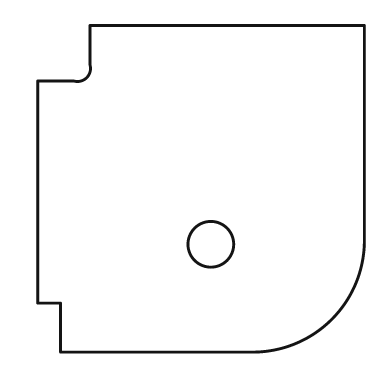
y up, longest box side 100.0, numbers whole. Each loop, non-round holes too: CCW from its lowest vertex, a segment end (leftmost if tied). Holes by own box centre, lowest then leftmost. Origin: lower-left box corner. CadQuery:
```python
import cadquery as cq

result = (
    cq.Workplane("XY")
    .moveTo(7.0, 0.0)
    .lineTo(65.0, 0.0)
    .threePointArc((90.0, 10.0), (100.0, 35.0))
    .lineTo(100.0, 100.0)
    .lineTo(16.0, 100.0)
    .lineTo(16.0, 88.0)
    .threePointArc((15.0, 84.0), (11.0, 83.0))
    .lineTo(0.0, 83.0)
    .lineTo(0.0, 15.0)
    .lineTo(7.0, 15.0)
    .close()
    .moveTo(53.0, 33.0)
    .circle(7.0)
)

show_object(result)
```